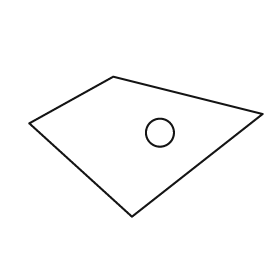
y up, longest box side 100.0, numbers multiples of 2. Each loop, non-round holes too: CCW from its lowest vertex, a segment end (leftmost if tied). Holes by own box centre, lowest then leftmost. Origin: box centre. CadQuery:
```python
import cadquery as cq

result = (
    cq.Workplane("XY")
    .moveTo(-6.0, -30.0)
    .lineTo(50.0, 14.0)
    .lineTo(-14.0, 30.0)
    .lineTo(-50.0, 10.0)
    .close()
    .moveTo(6.0, 6.0)
    .circle(6.0)
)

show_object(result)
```